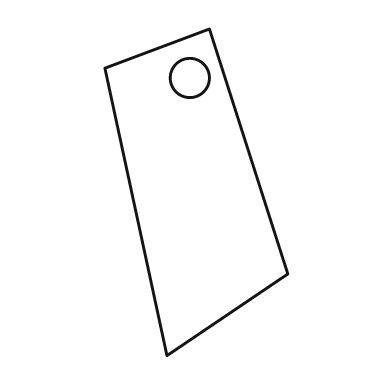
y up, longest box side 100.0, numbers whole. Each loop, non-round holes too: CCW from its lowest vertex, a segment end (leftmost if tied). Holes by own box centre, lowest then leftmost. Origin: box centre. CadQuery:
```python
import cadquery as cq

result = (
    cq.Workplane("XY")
    .moveTo(-9.0, -50.0)
    .lineTo(28.0, -25.0)
    .lineTo(4.0, 50.0)
    .lineTo(-28.0, 38.0)
    .close()
    .moveTo(-2.0, 35.0)
    .circle(6.0)
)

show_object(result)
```